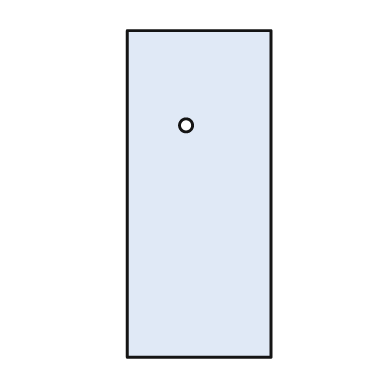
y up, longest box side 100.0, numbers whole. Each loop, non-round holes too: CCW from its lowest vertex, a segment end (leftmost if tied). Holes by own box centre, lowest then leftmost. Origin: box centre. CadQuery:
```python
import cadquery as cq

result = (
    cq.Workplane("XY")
    .moveTo(-22.0, -50.0)
    .lineTo(22.0, -50.0)
    .lineTo(22.0, 50.0)
    .lineTo(-22.0, 50.0)
    .close()
    .moveTo(-4.0, 21.0)
    .circle(2.0)
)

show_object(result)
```